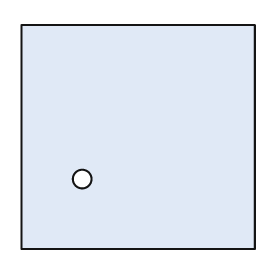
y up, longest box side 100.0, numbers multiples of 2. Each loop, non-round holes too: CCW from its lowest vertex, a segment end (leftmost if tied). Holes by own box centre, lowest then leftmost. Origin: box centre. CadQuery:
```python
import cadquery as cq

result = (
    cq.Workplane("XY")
    .moveTo(-50.0, -48.0)
    .lineTo(50.0, -48.0)
    .lineTo(50.0, 48.0)
    .lineTo(-50.0, 48.0)
    .close()
    .moveTo(-24.0, -18.0)
    .circle(4.0)
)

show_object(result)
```